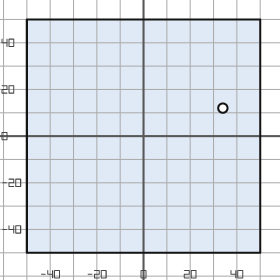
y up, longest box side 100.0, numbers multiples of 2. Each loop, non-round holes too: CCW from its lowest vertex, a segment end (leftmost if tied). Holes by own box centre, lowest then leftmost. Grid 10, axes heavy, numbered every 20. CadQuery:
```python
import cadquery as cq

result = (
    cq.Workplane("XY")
    .moveTo(-50.0, -50.0)
    .lineTo(50.0, -50.0)
    .lineTo(50.0, 50.0)
    .lineTo(-50.0, 50.0)
    .close()
    .moveTo(34.0, 12.0)
    .circle(2.0)
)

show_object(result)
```